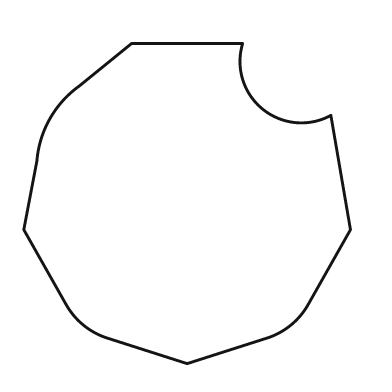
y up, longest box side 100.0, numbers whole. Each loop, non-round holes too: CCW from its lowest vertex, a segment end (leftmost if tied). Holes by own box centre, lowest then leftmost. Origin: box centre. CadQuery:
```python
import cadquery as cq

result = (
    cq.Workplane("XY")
    .moveTo(0.0, -49.0)
    .lineTo(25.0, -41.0)
    .threePointArc((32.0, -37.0), (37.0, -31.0))
    .lineTo(50.0, -8.0)
    .lineTo(44.0, 27.0)
    .threePointArc((23.0, 29.0), (17.0, 49.0))
    .lineTo(-17.0, 49.0)
    .lineTo(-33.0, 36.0)
    .threePointArc((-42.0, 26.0), (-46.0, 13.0))
    .lineTo(-50.0, -8.0)
    .lineTo(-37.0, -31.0)
    .threePointArc((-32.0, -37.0), (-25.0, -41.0))
    .close()
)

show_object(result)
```